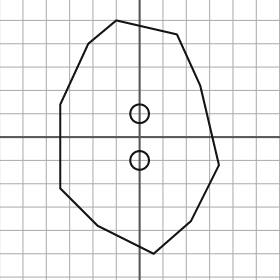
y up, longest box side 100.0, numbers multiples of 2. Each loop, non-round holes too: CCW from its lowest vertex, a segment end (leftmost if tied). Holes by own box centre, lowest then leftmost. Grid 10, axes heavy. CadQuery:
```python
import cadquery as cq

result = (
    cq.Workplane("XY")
    .moveTo(6.0, -50.0)
    .lineTo(22.0, -36.0)
    .lineTo(34.0, -12.0)
    .lineTo(26.0, 22.0)
    .lineTo(16.0, 44.0)
    .lineTo(-10.0, 50.0)
    .lineTo(-22.0, 40.0)
    .lineTo(-34.0, 14.0)
    .lineTo(-34.0, -22.0)
    .lineTo(-18.0, -38.0)
    .close()
    .moveTo(0.0, -10.0)
    .circle(4.0)
    .moveTo(0.0, 10.0)
    .circle(4.0)
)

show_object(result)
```